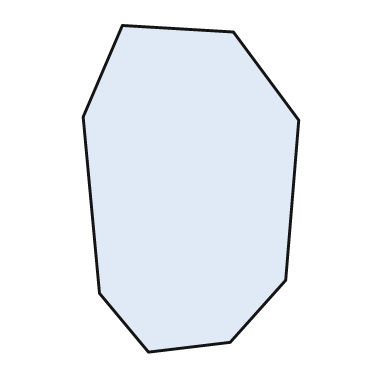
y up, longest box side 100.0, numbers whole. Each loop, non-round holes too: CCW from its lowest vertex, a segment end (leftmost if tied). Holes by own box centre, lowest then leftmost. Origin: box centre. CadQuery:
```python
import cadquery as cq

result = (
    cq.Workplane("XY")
    .moveTo(-13.0, -50.0)
    .lineTo(12.0, -47.0)
    .lineTo(29.0, -28.0)
    .lineTo(33.0, 21.0)
    .lineTo(13.0, 48.0)
    .lineTo(-21.0, 50.0)
    .lineTo(-33.0, 22.0)
    .lineTo(-28.0, -32.0)
    .close()
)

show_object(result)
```